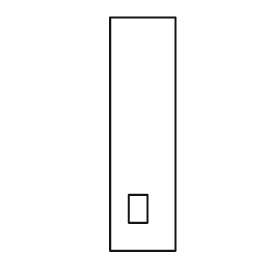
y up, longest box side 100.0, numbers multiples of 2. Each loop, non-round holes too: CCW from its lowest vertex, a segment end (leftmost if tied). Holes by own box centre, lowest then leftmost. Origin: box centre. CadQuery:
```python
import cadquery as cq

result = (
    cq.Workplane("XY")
    .moveTo(-14.0, -50.0)
    .lineTo(14.0, -50.0)
    .lineTo(14.0, 50.0)
    .lineTo(-14.0, 50.0)
    .close()
    .moveTo(-6.0, -38.0)
    .lineTo(2.0, -38.0)
    .lineTo(2.0, -26.0)
    .lineTo(-6.0, -26.0)
    .close()
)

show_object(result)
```